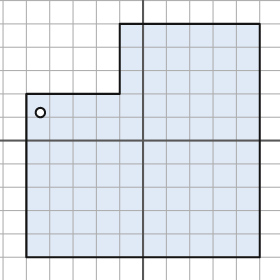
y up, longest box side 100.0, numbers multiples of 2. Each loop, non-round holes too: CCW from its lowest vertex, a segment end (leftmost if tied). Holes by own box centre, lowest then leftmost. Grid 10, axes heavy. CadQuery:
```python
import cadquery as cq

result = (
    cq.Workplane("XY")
    .moveTo(-50.0, -50.0)
    .lineTo(50.0, -50.0)
    .lineTo(50.0, 50.0)
    .lineTo(-10.0, 50.0)
    .lineTo(-10.0, 20.0)
    .lineTo(-50.0, 20.0)
    .close()
    .moveTo(-44.0, 12.0)
    .circle(2.0)
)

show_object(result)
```